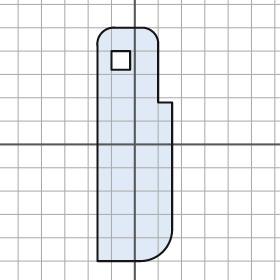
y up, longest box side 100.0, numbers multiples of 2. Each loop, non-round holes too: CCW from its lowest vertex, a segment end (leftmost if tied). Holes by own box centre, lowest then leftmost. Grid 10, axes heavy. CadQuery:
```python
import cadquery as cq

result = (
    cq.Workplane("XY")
    .moveTo(-16.0, -50.0)
    .lineTo(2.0, -50.0)
    .threePointArc((12.0, -46.0), (16.0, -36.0))
    .lineTo(16.0, 18.0)
    .lineTo(10.0, 18.0)
    .lineTo(10.0, 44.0)
    .threePointArc((8.0, 48.0), (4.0, 50.0))
    .lineTo(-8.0, 50.0)
    .threePointArc((-14.0, 48.0), (-16.0, 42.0))
    .close()
    .moveTo(-10.0, 32.0)
    .lineTo(-2.0, 32.0)
    .lineTo(-2.0, 40.0)
    .lineTo(-10.0, 40.0)
    .close()
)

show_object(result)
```